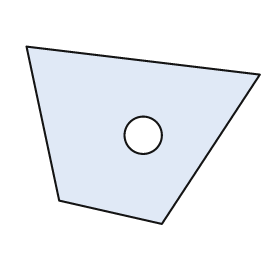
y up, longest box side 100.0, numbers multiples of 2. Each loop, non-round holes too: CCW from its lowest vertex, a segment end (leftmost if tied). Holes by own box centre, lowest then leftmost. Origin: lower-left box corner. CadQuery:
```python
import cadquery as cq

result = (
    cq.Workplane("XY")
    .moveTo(58.0, 0.0)
    .lineTo(100.0, 64.0)
    .lineTo(0.0, 76.0)
    .lineTo(14.0, 10.0)
    .close()
    .moveTo(50.0, 38.0)
    .circle(8.0)
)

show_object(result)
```